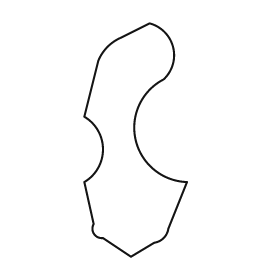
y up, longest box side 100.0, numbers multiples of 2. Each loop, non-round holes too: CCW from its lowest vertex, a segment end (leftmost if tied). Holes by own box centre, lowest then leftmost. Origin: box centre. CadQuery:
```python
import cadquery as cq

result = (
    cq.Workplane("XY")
    .moveTo(-2.0, -50.0)
    .lineTo(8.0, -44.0)
    .threePointArc((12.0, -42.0), (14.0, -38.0))
    .lineTo(22.0, -18.0)
    .threePointArc((0.0, 0.0), (12.0, 26.0))
    .threePointArc((16.0, 40.0), (6.0, 50.0))
    .lineTo(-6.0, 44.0)
    .threePointArc((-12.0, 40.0), (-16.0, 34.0))
    .lineTo(-22.0, 10.0)
    .threePointArc((-14.0, -4.0), (-22.0, -18.0))
    .lineTo(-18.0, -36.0)
    .threePointArc((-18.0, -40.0), (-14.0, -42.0))
    .close()
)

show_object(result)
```